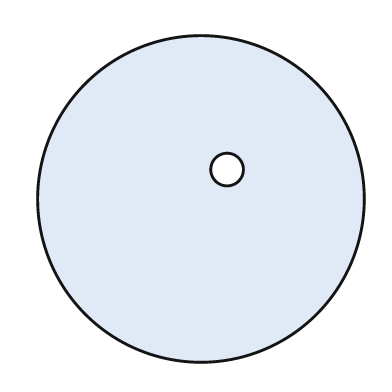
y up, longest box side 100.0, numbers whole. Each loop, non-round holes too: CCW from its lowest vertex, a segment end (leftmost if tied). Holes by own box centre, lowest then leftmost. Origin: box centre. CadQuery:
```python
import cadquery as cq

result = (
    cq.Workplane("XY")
    .moveTo(0.0, 0.0)
    .circle(50.0)
    .moveTo(8.0, 9.0)
    .circle(5.0)
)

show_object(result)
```